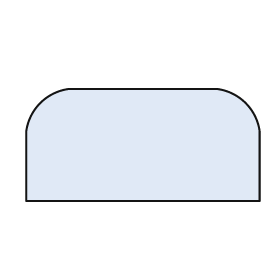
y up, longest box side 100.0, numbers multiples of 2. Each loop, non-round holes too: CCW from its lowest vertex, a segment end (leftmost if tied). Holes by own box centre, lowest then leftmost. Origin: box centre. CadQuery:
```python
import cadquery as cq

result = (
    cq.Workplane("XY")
    .moveTo(-50.0, -24.0)
    .lineTo(50.0, -24.0)
    .lineTo(50.0, 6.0)
    .threePointArc((44.0, 18.0), (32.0, 24.0))
    .lineTo(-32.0, 24.0)
    .threePointArc((-44.0, 18.0), (-50.0, 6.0))
    .close()
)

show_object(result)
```